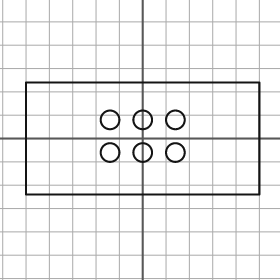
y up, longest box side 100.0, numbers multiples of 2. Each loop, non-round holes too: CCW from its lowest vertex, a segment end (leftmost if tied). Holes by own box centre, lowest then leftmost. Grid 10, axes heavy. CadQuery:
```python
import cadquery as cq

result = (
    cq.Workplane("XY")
    .moveTo(-50.0, -24.0)
    .lineTo(50.0, -24.0)
    .lineTo(50.0, 24.0)
    .lineTo(-50.0, 24.0)
    .close()
    .moveTo(-14.0, -6.0)
    .circle(4.0)
    .moveTo(0.0, -6.0)
    .circle(4.0)
    .moveTo(14.0, -6.0)
    .circle(4.0)
    .moveTo(-14.0, 8.0)
    .circle(4.0)
    .moveTo(0.0, 8.0)
    .circle(4.0)
    .moveTo(14.0, 8.0)
    .circle(4.0)
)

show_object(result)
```